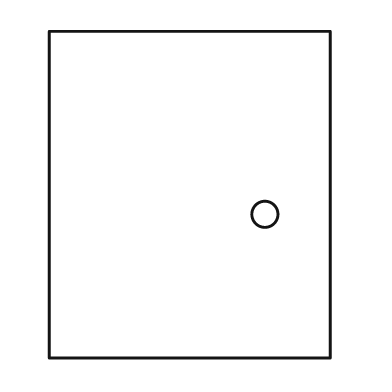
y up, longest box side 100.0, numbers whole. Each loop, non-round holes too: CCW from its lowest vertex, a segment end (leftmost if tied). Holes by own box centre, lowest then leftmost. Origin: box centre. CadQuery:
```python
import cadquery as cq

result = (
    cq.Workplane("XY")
    .moveTo(-43.0, -50.0)
    .lineTo(43.0, -50.0)
    .lineTo(43.0, 50.0)
    .lineTo(-43.0, 50.0)
    .close()
    .moveTo(23.0, -6.0)
    .circle(4.0)
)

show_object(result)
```